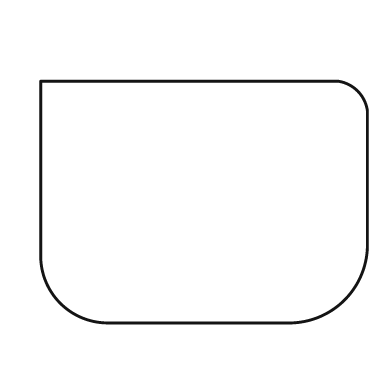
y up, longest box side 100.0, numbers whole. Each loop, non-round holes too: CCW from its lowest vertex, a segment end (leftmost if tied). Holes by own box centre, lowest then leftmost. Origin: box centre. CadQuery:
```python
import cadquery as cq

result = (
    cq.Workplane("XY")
    .moveTo(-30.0, -37.0)
    .lineTo(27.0, -37.0)
    .threePointArc((43.0, -30.0), (50.0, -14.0))
    .lineTo(50.0, 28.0)
    .threePointArc((47.0, 34.0), (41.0, 37.0))
    .lineTo(-50.0, 37.0)
    .lineTo(-50.0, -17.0)
    .threePointArc((-44.0, -31.0), (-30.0, -37.0))
    .close()
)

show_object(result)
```